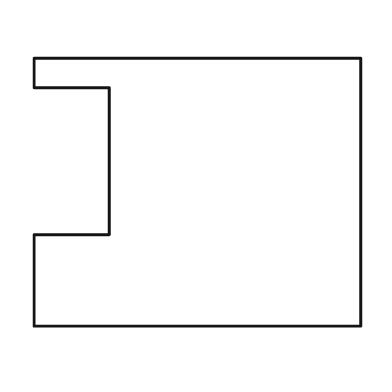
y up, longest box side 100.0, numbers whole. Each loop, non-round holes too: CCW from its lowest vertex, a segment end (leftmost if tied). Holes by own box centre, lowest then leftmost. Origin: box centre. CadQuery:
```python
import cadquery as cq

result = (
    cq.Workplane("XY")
    .moveTo(-50.0, -41.0)
    .lineTo(50.0, -41.0)
    .lineTo(50.0, 41.0)
    .lineTo(-50.0, 41.0)
    .lineTo(-50.0, 32.0)
    .lineTo(-27.0, 32.0)
    .lineTo(-27.0, -13.0)
    .lineTo(-50.0, -13.0)
    .close()
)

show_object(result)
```